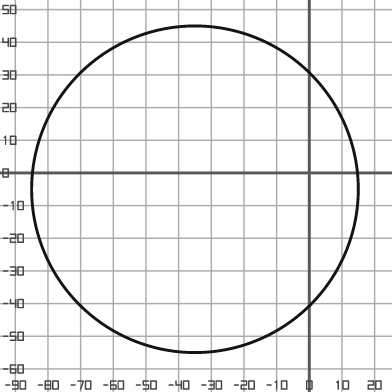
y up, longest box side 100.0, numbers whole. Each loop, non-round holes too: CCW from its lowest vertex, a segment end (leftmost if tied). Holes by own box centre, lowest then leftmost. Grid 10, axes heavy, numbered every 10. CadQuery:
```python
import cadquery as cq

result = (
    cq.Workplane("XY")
    .moveTo(-35.0, -5.0)
    .circle(50.0)
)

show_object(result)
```